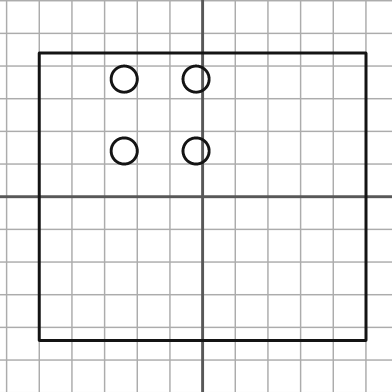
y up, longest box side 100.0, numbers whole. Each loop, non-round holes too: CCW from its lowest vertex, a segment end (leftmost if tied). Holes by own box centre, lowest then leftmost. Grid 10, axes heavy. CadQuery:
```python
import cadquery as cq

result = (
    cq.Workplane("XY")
    .moveTo(-50.0, -44.0)
    .lineTo(50.0, -44.0)
    .lineTo(50.0, 44.0)
    .lineTo(-50.0, 44.0)
    .close()
    .moveTo(-24.0, 14.0)
    .circle(4.0)
    .moveTo(-2.0, 14.0)
    .circle(4.0)
    .moveTo(-24.0, 36.0)
    .circle(4.0)
    .moveTo(-2.0, 36.0)
    .circle(4.0)
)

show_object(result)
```